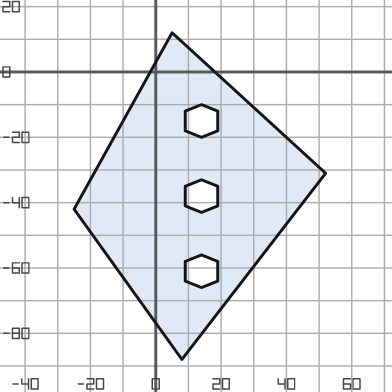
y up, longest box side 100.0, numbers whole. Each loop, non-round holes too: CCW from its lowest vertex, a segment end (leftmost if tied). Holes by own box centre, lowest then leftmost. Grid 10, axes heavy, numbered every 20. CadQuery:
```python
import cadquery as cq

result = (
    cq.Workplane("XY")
    .moveTo(8.0, -88.0)
    .lineTo(52.0, -31.0)
    .lineTo(5.0, 12.0)
    .lineTo(-25.0, -42.0)
    .close()
    .moveTo(14.0, -66.0)
    .lineTo(19.0, -64.0)
    .lineTo(19.0, -58.0)
    .lineTo(14.0, -56.0)
    .lineTo(9.0, -58.0)
    .lineTo(9.0, -64.0)
    .close()
    .moveTo(14.0, -43.0)
    .lineTo(19.0, -41.0)
    .lineTo(19.0, -35.0)
    .lineTo(14.0, -33.0)
    .lineTo(9.0, -35.0)
    .lineTo(9.0, -41.0)
    .close()
    .moveTo(14.0, -20.0)
    .lineTo(19.0, -18.0)
    .lineTo(19.0, -12.0)
    .lineTo(14.0, -10.0)
    .lineTo(9.0, -12.0)
    .lineTo(9.0, -18.0)
    .close()
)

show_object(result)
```